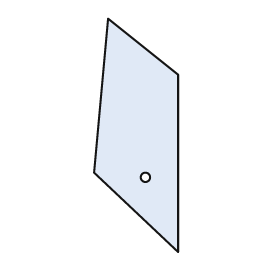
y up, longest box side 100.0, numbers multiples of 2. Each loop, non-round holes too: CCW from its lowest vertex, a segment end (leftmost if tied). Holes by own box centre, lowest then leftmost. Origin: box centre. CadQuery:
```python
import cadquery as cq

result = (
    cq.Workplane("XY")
    .moveTo(18.0, -50.0)
    .lineTo(18.0, 26.0)
    .lineTo(-12.0, 50.0)
    .lineTo(-18.0, -16.0)
    .close()
    .moveTo(4.0, -18.0)
    .circle(2.0)
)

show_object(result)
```